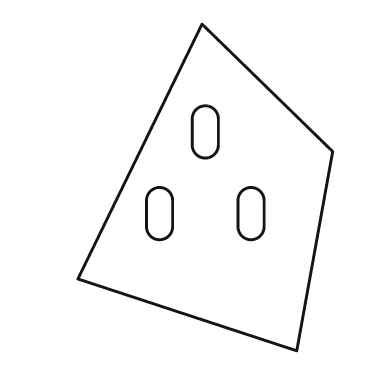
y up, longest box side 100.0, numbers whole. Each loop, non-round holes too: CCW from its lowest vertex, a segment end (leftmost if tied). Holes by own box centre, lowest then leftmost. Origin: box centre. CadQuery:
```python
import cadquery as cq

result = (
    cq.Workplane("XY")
    .moveTo(28.0, -50.0)
    .lineTo(39.0, 11.0)
    .lineTo(-1.0, 50.0)
    .lineTo(-39.0, -28.0)
    .close()
    .moveTo(-18.0, -12.0)
    .threePointArc((-14.0, -16.0), (-10.0, -12.0))
    .lineTo(-10.0, -4.0)
    .threePointArc((-14.0, 0.0), (-18.0, -4.0))
    .close()
    .moveTo(10.0, -12.0)
    .threePointArc((14.0, -16.0), (18.0, -12.0))
    .lineTo(18.0, -4.0)
    .threePointArc((14.0, 0.0), (10.0, -4.0))
    .close()
    .moveTo(-4.0, 13.0)
    .threePointArc((0.0, 9.0), (4.0, 13.0))
    .lineTo(4.0, 21.0)
    .threePointArc((0.0, 25.0), (-4.0, 21.0))
    .close()
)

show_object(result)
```